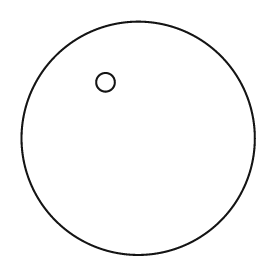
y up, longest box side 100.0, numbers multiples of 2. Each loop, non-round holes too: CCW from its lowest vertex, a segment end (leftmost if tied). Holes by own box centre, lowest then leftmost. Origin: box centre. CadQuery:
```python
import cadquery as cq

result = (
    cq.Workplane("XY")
    .moveTo(0.0, 0.0)
    .circle(50.0)
    .moveTo(-14.0, 24.0)
    .circle(4.0)
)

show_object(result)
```